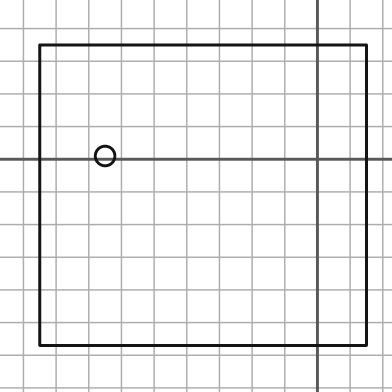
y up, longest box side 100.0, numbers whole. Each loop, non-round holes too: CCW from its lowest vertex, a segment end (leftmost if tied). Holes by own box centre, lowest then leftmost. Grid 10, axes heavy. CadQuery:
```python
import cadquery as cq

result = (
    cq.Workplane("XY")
    .moveTo(-85.0, -57.0)
    .lineTo(15.0, -57.0)
    .lineTo(15.0, 35.0)
    .lineTo(-85.0, 35.0)
    .close()
    .moveTo(-65.0, 1.0)
    .circle(3.0)
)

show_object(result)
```